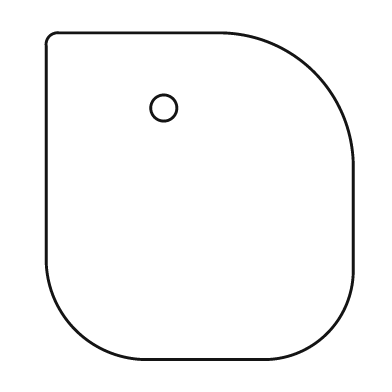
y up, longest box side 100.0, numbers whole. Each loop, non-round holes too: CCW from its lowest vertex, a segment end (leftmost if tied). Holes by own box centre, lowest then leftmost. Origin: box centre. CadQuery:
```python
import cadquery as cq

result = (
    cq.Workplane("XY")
    .moveTo(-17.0, -50.0)
    .lineTo(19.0, -50.0)
    .threePointArc((39.0, -42.0), (47.0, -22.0))
    .lineTo(47.0, 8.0)
    .threePointArc((35.0, 38.0), (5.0, 50.0))
    .lineTo(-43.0, 50.0)
    .threePointArc((-46.0, 49.0), (-47.0, 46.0))
    .lineTo(-47.0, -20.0)
    .threePointArc((-38.0, -41.0), (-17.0, -50.0))
    .close()
    .moveTo(-11.0, 27.0)
    .circle(4.0)
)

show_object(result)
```